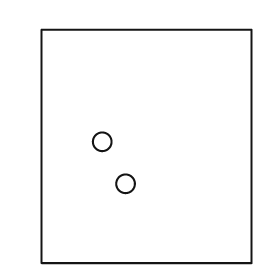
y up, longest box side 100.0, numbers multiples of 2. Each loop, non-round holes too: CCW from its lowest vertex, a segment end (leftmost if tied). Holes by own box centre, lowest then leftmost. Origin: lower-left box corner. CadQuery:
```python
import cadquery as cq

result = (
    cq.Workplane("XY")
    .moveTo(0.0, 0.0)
    .lineTo(90.0, 0.0)
    .lineTo(90.0, 100.0)
    .lineTo(0.0, 100.0)
    .close()
    .moveTo(36.0, 34.0)
    .circle(4.0)
    .moveTo(26.0, 52.0)
    .circle(4.0)
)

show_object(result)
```